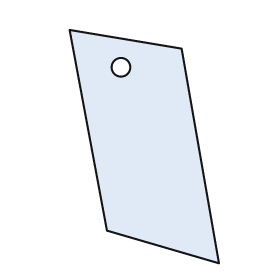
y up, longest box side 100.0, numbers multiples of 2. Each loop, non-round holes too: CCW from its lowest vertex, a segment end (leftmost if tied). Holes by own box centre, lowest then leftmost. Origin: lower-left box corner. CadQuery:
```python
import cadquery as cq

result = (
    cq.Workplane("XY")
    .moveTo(64.0, 0.0)
    .lineTo(48.0, 92.0)
    .lineTo(0.0, 100.0)
    .lineTo(16.0, 14.0)
    .close()
    .moveTo(22.0, 84.0)
    .circle(4.0)
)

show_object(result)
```